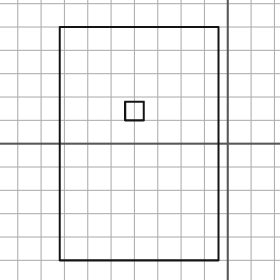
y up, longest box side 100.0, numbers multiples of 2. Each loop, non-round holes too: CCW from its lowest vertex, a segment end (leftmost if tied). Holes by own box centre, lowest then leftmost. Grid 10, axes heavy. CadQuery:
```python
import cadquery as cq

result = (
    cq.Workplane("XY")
    .moveTo(-72.0, -50.0)
    .lineTo(-4.0, -50.0)
    .lineTo(-4.0, 50.0)
    .lineTo(-72.0, 50.0)
    .close()
    .moveTo(-44.0, 10.0)
    .lineTo(-36.0, 10.0)
    .lineTo(-36.0, 18.0)
    .lineTo(-44.0, 18.0)
    .close()
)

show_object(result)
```